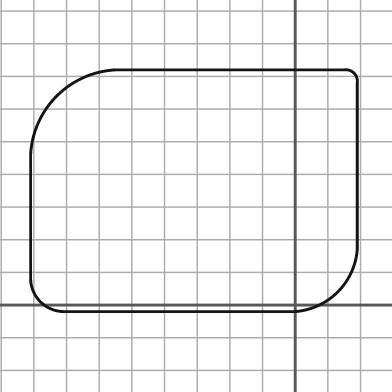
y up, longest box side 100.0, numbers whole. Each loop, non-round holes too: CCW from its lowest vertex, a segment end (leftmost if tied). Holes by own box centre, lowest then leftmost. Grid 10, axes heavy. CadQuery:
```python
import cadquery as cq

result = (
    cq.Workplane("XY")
    .moveTo(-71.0, -2.0)
    .lineTo(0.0, -2.0)
    .threePointArc((13.0, 4.0), (19.0, 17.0))
    .lineTo(19.0, 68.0)
    .threePointArc((18.0, 71.0), (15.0, 72.0))
    .lineTo(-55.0, 72.0)
    .threePointArc((-73.0, 64.0), (-81.0, 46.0))
    .lineTo(-81.0, 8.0)
    .threePointArc((-78.0, 1.0), (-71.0, -2.0))
    .close()
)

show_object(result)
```